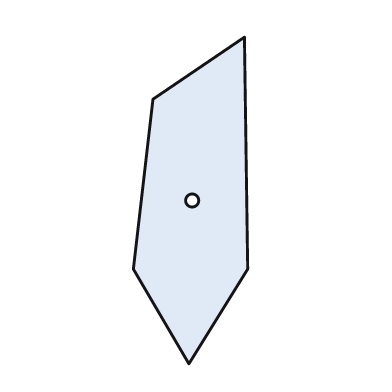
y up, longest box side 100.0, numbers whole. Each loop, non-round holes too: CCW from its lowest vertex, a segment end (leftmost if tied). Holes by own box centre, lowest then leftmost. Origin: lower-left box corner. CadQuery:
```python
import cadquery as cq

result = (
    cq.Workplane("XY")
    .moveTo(17.0, 0.0)
    .lineTo(35.0, 29.0)
    .lineTo(34.0, 100.0)
    .lineTo(6.0, 81.0)
    .lineTo(0.0, 29.0)
    .close()
    .moveTo(18.0, 50.0)
    .circle(2.0)
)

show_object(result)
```